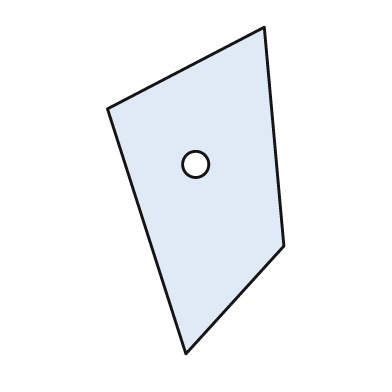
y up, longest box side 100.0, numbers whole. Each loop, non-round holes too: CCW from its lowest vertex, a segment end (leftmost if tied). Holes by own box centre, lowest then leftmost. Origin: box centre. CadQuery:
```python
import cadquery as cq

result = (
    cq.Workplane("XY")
    .moveTo(-3.0, -50.0)
    .lineTo(27.0, -17.0)
    .lineTo(21.0, 50.0)
    .lineTo(-27.0, 25.0)
    .close()
    .moveTo(0.0, 8.0)
    .circle(4.0)
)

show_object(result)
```